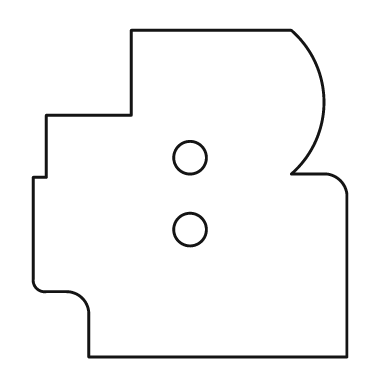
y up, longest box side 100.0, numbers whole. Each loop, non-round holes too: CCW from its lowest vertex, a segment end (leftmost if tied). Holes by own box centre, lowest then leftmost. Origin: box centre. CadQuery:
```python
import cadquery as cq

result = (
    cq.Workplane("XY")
    .moveTo(-31.0, -50.0)
    .lineTo(48.0, -50.0)
    .lineTo(48.0, 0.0)
    .threePointArc((46.0, 4.0), (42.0, 6.0))
    .lineTo(31.0, 6.0)
    .threePointArc((41.0, 28.0), (31.0, 50.0))
    .lineTo(-18.0, 50.0)
    .lineTo(-18.0, 24.0)
    .lineTo(-44.0, 24.0)
    .lineTo(-44.0, 5.0)
    .lineTo(-48.0, 5.0)
    .lineTo(-48.0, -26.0)
    .threePointArc((-47.0, -29.0), (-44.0, -30.0))
    .lineTo(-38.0, -30.0)
    .threePointArc((-33.0, -32.0), (-31.0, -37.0))
    .close()
    .moveTo(0.0, -11.0)
    .circle(5.0)
    .moveTo(0.0, 11.0)
    .circle(5.0)
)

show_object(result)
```